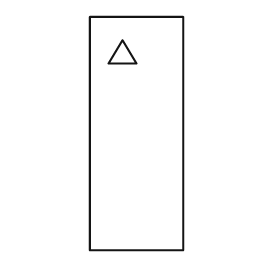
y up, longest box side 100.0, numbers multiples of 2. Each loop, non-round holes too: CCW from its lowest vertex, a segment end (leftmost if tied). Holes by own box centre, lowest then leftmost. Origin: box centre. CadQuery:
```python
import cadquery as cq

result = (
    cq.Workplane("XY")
    .moveTo(-20.0, -50.0)
    .lineTo(20.0, -50.0)
    .lineTo(20.0, 50.0)
    .lineTo(-20.0, 50.0)
    .close()
    .moveTo(-12.0, 30.0)
    .lineTo(0.0, 30.0)
    .lineTo(-6.0, 40.0)
    .close()
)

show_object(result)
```